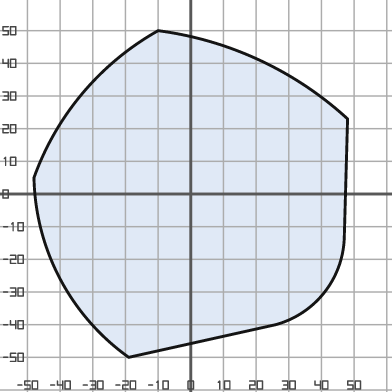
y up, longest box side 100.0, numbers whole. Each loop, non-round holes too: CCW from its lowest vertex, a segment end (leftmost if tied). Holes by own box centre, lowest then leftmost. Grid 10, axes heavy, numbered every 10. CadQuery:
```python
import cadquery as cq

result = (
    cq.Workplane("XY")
    .moveTo(-19.0, -50.0)
    .lineTo(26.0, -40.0)
    .threePointArc((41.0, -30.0), (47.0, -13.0))
    .lineTo(48.0, 23.0)
    .threePointArc((21.0, 41.0), (-10.0, 50.0))
    .threePointArc((-33.0, 31.0), (-48.0, 5.0))
    .threePointArc((-40.0, -26.0), (-19.0, -50.0))
    .close()
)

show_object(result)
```